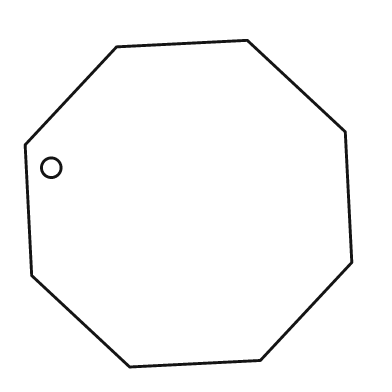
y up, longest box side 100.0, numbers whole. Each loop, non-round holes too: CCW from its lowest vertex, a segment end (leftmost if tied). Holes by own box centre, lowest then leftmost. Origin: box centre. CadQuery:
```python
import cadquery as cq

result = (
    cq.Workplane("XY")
    .moveTo(-18.0, -50.0)
    .lineTo(22.0, -48.0)
    .lineTo(50.0, -18.0)
    .lineTo(48.0, 22.0)
    .lineTo(18.0, 50.0)
    .lineTo(-22.0, 48.0)
    .lineTo(-50.0, 18.0)
    .lineTo(-48.0, -22.0)
    .close()
    .moveTo(-42.0, 11.0)
    .circle(3.0)
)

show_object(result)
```